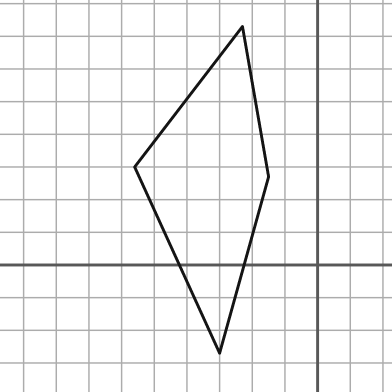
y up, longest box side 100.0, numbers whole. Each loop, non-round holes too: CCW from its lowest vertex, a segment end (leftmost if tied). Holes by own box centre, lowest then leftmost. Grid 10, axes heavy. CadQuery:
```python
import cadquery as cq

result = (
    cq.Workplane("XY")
    .moveTo(-30.0, -27.0)
    .lineTo(-15.0, 27.0)
    .lineTo(-23.0, 73.0)
    .lineTo(-56.0, 30.0)
    .close()
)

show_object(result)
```